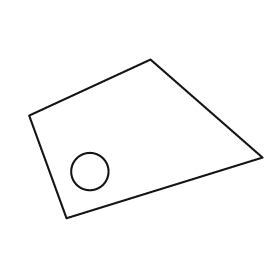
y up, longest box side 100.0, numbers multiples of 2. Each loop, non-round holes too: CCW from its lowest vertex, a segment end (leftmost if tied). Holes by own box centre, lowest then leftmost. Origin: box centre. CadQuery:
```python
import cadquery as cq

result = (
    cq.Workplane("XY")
    .moveTo(-34.0, -34.0)
    .lineTo(50.0, -8.0)
    .lineTo(2.0, 34.0)
    .lineTo(-50.0, 10.0)
    .close()
    .moveTo(-24.0, -14.0)
    .circle(8.0)
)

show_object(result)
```